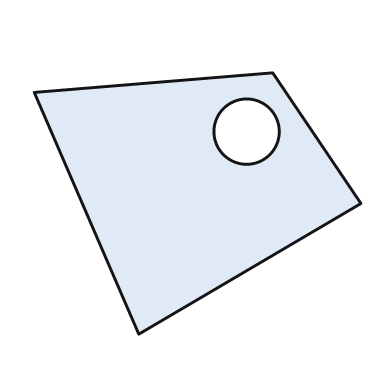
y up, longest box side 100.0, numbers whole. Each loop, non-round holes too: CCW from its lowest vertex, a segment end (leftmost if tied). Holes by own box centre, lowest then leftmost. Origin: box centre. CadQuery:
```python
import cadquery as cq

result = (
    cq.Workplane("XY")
    .moveTo(-18.0, -40.0)
    .lineTo(50.0, 0.0)
    .lineTo(23.0, 40.0)
    .lineTo(-50.0, 34.0)
    .close()
    .moveTo(15.0, 22.0)
    .circle(10.0)
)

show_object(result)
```